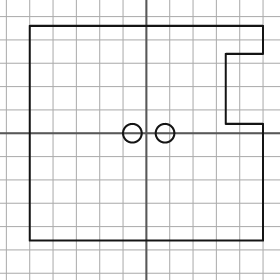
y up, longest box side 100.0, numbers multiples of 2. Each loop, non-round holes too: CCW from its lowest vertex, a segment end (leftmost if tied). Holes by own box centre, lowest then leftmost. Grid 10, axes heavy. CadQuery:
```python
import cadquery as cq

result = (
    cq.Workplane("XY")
    .moveTo(-50.0, -46.0)
    .lineTo(50.0, -46.0)
    .lineTo(50.0, 4.0)
    .lineTo(34.0, 4.0)
    .lineTo(34.0, 34.0)
    .lineTo(50.0, 34.0)
    .lineTo(50.0, 46.0)
    .lineTo(-50.0, 46.0)
    .close()
    .moveTo(-6.0, 0.0)
    .circle(4.0)
    .moveTo(8.0, 0.0)
    .circle(4.0)
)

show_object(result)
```